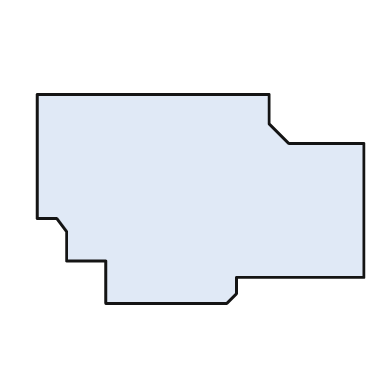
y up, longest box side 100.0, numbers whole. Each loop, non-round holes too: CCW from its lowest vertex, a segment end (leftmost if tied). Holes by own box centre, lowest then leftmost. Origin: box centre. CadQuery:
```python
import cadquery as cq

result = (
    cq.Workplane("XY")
    .moveTo(-29.0, -32.0)
    .lineTo(8.0, -32.0)
    .lineTo(11.0, -29.0)
    .lineTo(11.0, -24.0)
    .lineTo(50.0, -24.0)
    .lineTo(50.0, 17.0)
    .lineTo(27.0, 17.0)
    .lineTo(21.0, 23.0)
    .lineTo(21.0, 32.0)
    .lineTo(-50.0, 32.0)
    .lineTo(-50.0, -6.0)
    .lineTo(-44.0, -6.0)
    .lineTo(-41.0, -10.0)
    .lineTo(-41.0, -19.0)
    .lineTo(-29.0, -19.0)
    .close()
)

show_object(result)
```